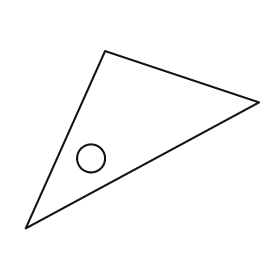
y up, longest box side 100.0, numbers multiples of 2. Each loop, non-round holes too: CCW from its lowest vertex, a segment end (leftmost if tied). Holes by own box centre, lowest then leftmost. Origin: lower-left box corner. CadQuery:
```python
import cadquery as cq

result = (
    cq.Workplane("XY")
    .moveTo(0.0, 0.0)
    .lineTo(100.0, 54.0)
    .lineTo(34.0, 76.0)
    .close()
    .moveTo(28.0, 30.0)
    .circle(6.0)
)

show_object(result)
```